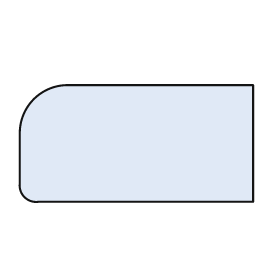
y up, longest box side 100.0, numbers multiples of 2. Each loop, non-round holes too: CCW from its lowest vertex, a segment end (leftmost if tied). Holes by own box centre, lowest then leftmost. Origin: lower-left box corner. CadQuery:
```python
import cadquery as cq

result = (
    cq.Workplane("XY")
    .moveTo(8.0, 0.0)
    .lineTo(100.0, 0.0)
    .lineTo(100.0, 50.0)
    .lineTo(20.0, 50.0)
    .threePointArc((6.0, 44.0), (0.0, 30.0))
    .lineTo(0.0, 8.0)
    .threePointArc((2.0, 2.0), (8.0, 0.0))
    .close()
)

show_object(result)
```